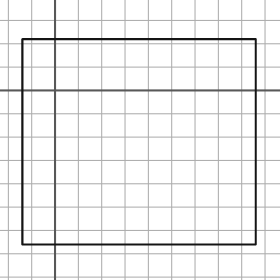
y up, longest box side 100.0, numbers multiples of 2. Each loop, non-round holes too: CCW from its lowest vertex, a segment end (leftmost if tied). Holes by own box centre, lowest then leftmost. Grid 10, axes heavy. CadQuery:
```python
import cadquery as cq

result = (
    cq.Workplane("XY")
    .moveTo(-14.0, -66.0)
    .lineTo(86.0, -66.0)
    .lineTo(86.0, 22.0)
    .lineTo(-14.0, 22.0)
    .close()
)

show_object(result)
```